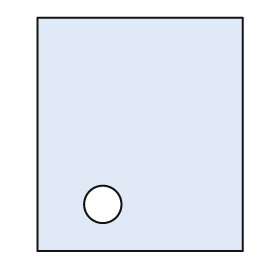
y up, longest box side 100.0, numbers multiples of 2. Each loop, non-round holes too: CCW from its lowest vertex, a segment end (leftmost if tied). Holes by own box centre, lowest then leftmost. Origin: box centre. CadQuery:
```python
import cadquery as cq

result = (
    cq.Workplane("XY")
    .moveTo(-44.0, -50.0)
    .lineTo(44.0, -50.0)
    .lineTo(44.0, 50.0)
    .lineTo(-44.0, 50.0)
    .close()
    .moveTo(-16.0, -30.0)
    .circle(8.0)
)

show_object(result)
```